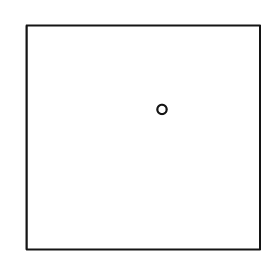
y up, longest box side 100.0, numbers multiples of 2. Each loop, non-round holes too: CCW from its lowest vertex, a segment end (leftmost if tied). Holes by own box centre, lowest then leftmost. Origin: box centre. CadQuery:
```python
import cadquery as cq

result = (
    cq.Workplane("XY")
    .moveTo(-50.0, -48.0)
    .lineTo(50.0, -48.0)
    .lineTo(50.0, 48.0)
    .lineTo(-50.0, 48.0)
    .close()
    .moveTo(8.0, 12.0)
    .circle(2.0)
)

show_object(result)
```